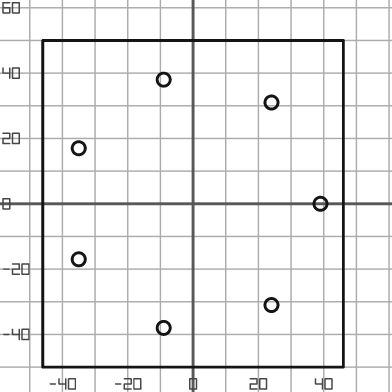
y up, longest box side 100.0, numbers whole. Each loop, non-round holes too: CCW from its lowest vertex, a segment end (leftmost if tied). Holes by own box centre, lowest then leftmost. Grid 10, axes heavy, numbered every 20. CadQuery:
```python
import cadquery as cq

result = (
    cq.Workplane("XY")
    .moveTo(-46.0, -50.0)
    .lineTo(46.0, -50.0)
    .lineTo(46.0, 50.0)
    .lineTo(-46.0, 50.0)
    .close()
    .moveTo(-9.0, -38.0)
    .circle(2.0)
    .moveTo(24.0, -31.0)
    .circle(2.0)
    .moveTo(-35.0, -17.0)
    .circle(2.0)
    .moveTo(39.0, 0.0)
    .circle(2.0)
    .moveTo(-35.0, 17.0)
    .circle(2.0)
    .moveTo(24.0, 31.0)
    .circle(2.0)
    .moveTo(-9.0, 38.0)
    .circle(2.0)
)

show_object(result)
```